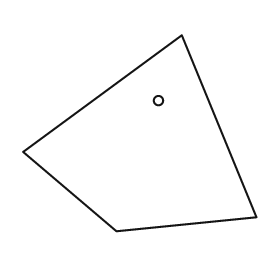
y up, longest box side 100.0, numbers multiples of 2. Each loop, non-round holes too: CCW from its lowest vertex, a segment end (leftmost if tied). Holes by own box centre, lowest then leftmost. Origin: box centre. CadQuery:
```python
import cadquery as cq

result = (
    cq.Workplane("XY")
    .moveTo(-10.0, -42.0)
    .lineTo(50.0, -36.0)
    .lineTo(18.0, 42.0)
    .lineTo(-50.0, -8.0)
    .close()
    .moveTo(8.0, 14.0)
    .circle(2.0)
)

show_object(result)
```